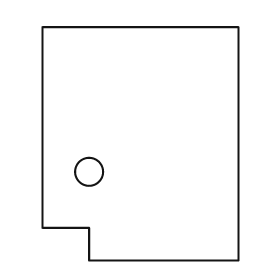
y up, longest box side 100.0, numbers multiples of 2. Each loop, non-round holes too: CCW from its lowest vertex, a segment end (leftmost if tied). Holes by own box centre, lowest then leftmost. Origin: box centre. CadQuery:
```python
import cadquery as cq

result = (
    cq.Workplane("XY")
    .moveTo(-22.0, -50.0)
    .lineTo(42.0, -50.0)
    .lineTo(42.0, 50.0)
    .lineTo(-42.0, 50.0)
    .lineTo(-42.0, -36.0)
    .lineTo(-22.0, -36.0)
    .close()
    .moveTo(-22.0, -12.0)
    .circle(6.0)
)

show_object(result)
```